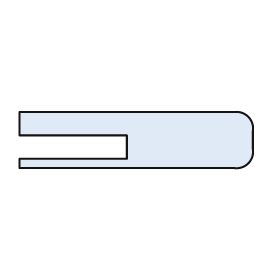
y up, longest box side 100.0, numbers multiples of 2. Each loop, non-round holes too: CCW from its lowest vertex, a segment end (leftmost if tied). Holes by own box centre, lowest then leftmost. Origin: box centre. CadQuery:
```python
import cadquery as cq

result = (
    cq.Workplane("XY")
    .moveTo(-50.0, -12.0)
    .lineTo(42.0, -12.0)
    .threePointArc((48.0, -10.0), (50.0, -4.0))
    .lineTo(50.0, 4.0)
    .threePointArc((48.0, 10.0), (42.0, 12.0))
    .lineTo(-50.0, 12.0)
    .lineTo(-50.0, 2.0)
    .lineTo(-4.0, 2.0)
    .lineTo(-4.0, -8.0)
    .lineTo(-50.0, -8.0)
    .close()
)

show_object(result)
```